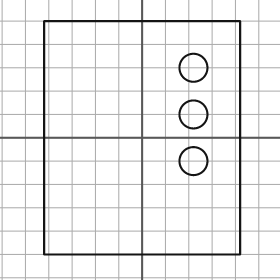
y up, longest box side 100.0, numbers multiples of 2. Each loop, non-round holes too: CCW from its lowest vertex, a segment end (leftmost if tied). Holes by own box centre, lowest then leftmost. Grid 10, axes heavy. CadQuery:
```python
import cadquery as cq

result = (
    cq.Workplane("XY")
    .moveTo(-42.0, -50.0)
    .lineTo(42.0, -50.0)
    .lineTo(42.0, 50.0)
    .lineTo(-42.0, 50.0)
    .close()
    .moveTo(22.0, -10.0)
    .circle(6.0)
    .moveTo(22.0, 10.0)
    .circle(6.0)
    .moveTo(22.0, 30.0)
    .circle(6.0)
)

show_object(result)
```